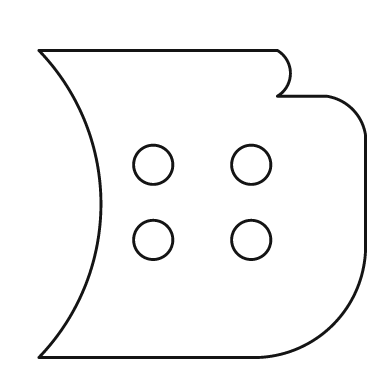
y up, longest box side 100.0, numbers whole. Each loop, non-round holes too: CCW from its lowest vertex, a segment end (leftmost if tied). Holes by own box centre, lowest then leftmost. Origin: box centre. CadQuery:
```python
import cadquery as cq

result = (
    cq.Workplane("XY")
    .moveTo(-50.0, -47.0)
    .lineTo(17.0, -47.0)
    .threePointArc((40.0, -37.0), (50.0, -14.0))
    .lineTo(50.0, 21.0)
    .threePointArc((46.0, 29.0), (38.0, 33.0))
    .lineTo(23.0, 33.0)
    .threePointArc((27.0, 40.0), (23.0, 47.0))
    .lineTo(-50.0, 47.0)
    .threePointArc((-31.0, 0.0), (-50.0, -47.0))
    .close()
    .moveTo(-15.0, -11.0)
    .circle(6.0)
    .moveTo(15.0, -11.0)
    .circle(6.0)
    .moveTo(-15.0, 12.0)
    .circle(6.0)
    .moveTo(15.0, 12.0)
    .circle(6.0)
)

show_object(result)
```